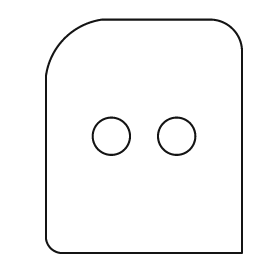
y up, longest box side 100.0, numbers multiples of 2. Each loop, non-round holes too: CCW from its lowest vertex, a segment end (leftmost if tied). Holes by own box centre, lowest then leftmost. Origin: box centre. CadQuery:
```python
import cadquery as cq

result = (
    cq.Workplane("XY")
    .moveTo(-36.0, -50.0)
    .lineTo(42.0, -50.0)
    .lineTo(42.0, 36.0)
    .threePointArc((38.0, 46.0), (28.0, 50.0))
    .lineTo(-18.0, 50.0)
    .threePointArc((-34.0, 42.0), (-42.0, 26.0))
    .lineTo(-42.0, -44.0)
    .threePointArc((-40.0, -48.0), (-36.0, -50.0))
    .close()
    .moveTo(-14.0, 0.0)
    .circle(8.0)
    .moveTo(14.0, 0.0)
    .circle(8.0)
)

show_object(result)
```